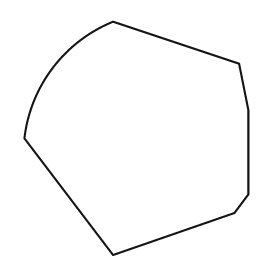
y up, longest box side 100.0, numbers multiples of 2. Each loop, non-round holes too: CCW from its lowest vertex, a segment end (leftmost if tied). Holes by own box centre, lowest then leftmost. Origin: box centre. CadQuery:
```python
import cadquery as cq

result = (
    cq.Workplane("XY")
    .moveTo(-10.0, -50.0)
    .lineTo(42.0, -32.0)
    .lineTo(48.0, -24.0)
    .lineTo(48.0, 12.0)
    .lineTo(44.0, 32.0)
    .lineTo(-10.0, 50.0)
    .threePointArc((-36.0, 30.0), (-48.0, 0.0))
    .close()
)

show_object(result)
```